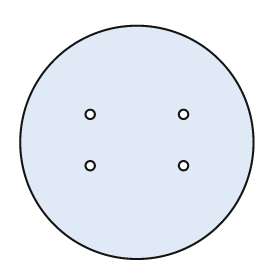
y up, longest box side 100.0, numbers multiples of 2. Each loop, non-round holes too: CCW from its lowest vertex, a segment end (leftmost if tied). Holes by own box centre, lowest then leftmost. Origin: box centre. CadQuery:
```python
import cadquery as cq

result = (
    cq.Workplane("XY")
    .moveTo(0.0, 0.0)
    .circle(50.0)
    .moveTo(-20.0, -10.0)
    .circle(2.0)
    .moveTo(20.0, -10.0)
    .circle(2.0)
    .moveTo(-20.0, 12.0)
    .circle(2.0)
    .moveTo(20.0, 12.0)
    .circle(2.0)
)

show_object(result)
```